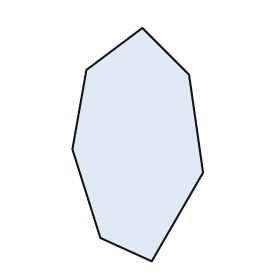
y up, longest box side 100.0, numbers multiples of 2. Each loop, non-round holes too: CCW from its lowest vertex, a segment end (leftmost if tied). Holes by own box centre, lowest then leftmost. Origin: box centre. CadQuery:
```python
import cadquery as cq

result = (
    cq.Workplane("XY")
    .moveTo(6.0, -50.0)
    .lineTo(28.0, -12.0)
    .lineTo(22.0, 30.0)
    .lineTo(2.0, 50.0)
    .lineTo(-22.0, 32.0)
    .lineTo(-28.0, -2.0)
    .lineTo(-16.0, -40.0)
    .close()
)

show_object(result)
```